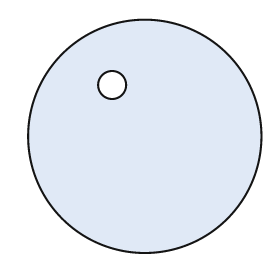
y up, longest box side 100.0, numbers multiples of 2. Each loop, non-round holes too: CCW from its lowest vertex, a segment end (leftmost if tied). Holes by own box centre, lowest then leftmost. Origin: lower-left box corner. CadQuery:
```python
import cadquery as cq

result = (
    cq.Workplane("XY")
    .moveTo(50.0, 50.0)
    .circle(50.0)
    .moveTo(36.0, 72.0)
    .circle(6.0)
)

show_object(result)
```